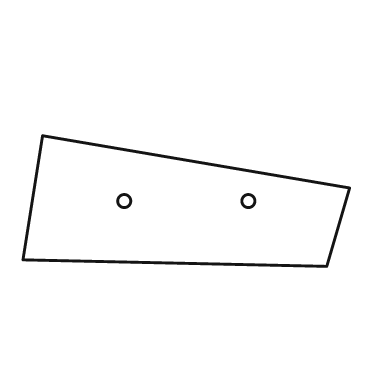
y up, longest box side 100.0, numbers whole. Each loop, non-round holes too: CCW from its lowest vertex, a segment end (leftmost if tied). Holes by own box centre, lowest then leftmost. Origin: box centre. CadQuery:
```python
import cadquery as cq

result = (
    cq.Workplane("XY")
    .moveTo(43.0, -20.0)
    .lineTo(50.0, 4.0)
    .lineTo(-44.0, 20.0)
    .lineTo(-50.0, -18.0)
    .close()
    .moveTo(-19.0, 0.0)
    .circle(2.0)
    .moveTo(19.0, 0.0)
    .circle(2.0)
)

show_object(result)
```